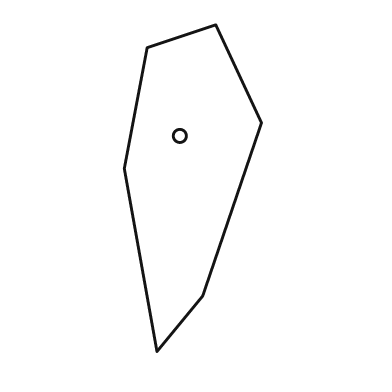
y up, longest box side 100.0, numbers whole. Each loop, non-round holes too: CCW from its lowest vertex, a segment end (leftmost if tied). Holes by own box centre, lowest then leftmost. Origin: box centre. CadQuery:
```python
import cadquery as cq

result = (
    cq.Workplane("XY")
    .moveTo(-11.0, -50.0)
    .lineTo(3.0, -33.0)
    .lineTo(21.0, 20.0)
    .lineTo(7.0, 50.0)
    .lineTo(-14.0, 43.0)
    .lineTo(-21.0, 6.0)
    .close()
    .moveTo(-4.0, 16.0)
    .circle(2.0)
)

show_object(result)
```